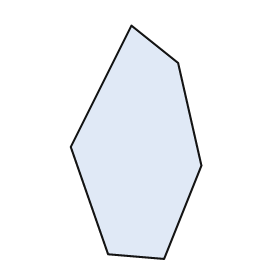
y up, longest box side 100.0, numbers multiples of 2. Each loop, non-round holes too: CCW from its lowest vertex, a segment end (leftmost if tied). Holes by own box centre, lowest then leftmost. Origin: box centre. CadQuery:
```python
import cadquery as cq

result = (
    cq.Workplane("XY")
    .moveTo(12.0, -50.0)
    .lineTo(28.0, -10.0)
    .lineTo(18.0, 34.0)
    .lineTo(-2.0, 50.0)
    .lineTo(-28.0, -2.0)
    .lineTo(-12.0, -48.0)
    .close()
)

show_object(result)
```